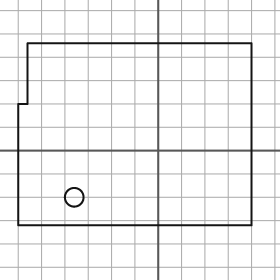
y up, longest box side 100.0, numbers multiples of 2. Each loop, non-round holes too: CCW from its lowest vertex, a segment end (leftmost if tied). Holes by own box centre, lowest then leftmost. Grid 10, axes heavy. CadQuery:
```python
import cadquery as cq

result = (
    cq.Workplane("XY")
    .moveTo(-60.0, -32.0)
    .lineTo(40.0, -32.0)
    .lineTo(40.0, 46.0)
    .lineTo(-56.0, 46.0)
    .lineTo(-56.0, 20.0)
    .lineTo(-60.0, 20.0)
    .close()
    .moveTo(-36.0, -20.0)
    .circle(4.0)
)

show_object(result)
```